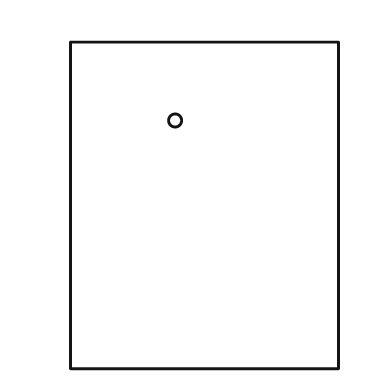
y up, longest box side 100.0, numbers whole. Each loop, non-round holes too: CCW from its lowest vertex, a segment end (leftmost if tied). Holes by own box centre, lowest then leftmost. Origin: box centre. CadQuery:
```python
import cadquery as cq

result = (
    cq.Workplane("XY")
    .moveTo(-41.0, -50.0)
    .lineTo(41.0, -50.0)
    .lineTo(41.0, 50.0)
    .lineTo(-41.0, 50.0)
    .close()
    .moveTo(-9.0, 26.0)
    .circle(2.0)
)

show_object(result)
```